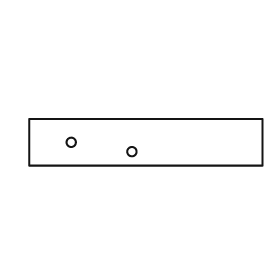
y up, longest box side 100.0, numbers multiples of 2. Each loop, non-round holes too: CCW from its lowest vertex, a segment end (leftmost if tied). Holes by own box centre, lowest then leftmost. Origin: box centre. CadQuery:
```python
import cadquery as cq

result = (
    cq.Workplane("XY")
    .moveTo(-50.0, -10.0)
    .lineTo(50.0, -10.0)
    .lineTo(50.0, 10.0)
    .lineTo(-50.0, 10.0)
    .close()
    .moveTo(-6.0, -4.0)
    .circle(2.0)
    .moveTo(-32.0, 0.0)
    .circle(2.0)
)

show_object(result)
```